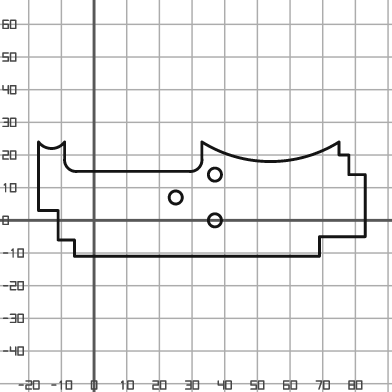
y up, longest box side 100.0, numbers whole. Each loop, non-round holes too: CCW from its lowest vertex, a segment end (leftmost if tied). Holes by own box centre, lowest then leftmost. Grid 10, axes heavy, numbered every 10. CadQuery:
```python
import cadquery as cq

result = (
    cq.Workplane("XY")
    .moveTo(-6.0, -11.0)
    .lineTo(69.0, -11.0)
    .lineTo(69.0, -5.0)
    .lineTo(83.0, -5.0)
    .lineTo(83.0, 14.0)
    .lineTo(78.0, 14.0)
    .lineTo(78.0, 20.0)
    .lineTo(75.0, 20.0)
    .lineTo(75.0, 24.0)
    .threePointArc((54.0, 18.0), (33.0, 24.0))
    .lineTo(33.0, 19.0)
    .threePointArc((32.0, 16.0), (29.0, 15.0))
    .lineTo(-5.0, 15.0)
    .threePointArc((-8.0, 16.0), (-9.0, 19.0))
    .lineTo(-9.0, 24.0)
    .threePointArc((-13.0, 22.0), (-17.0, 24.0))
    .lineTo(-17.0, 3.0)
    .lineTo(-11.0, 3.0)
    .lineTo(-11.0, -6.0)
    .lineTo(-6.0, -6.0)
    .close()
    .moveTo(37.0, 0.0)
    .circle(2.0)
    .moveTo(25.0, 7.0)
    .circle(2.0)
    .moveTo(37.0, 14.0)
    .circle(2.0)
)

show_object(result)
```